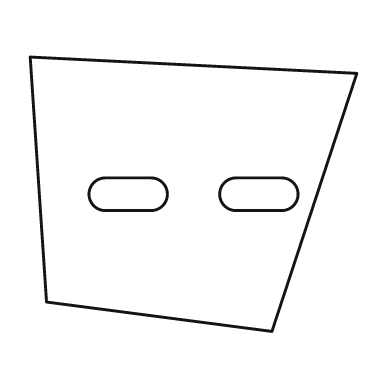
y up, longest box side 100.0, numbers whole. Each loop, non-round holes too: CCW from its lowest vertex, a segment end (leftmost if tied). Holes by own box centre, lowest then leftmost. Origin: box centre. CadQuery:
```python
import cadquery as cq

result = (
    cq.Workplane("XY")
    .moveTo(24.0, -42.0)
    .lineTo(50.0, 37.0)
    .lineTo(-50.0, 42.0)
    .lineTo(-45.0, -33.0)
    .close()
    .moveTo(-27.0, -5.0)
    .lineTo(-13.0, -5.0)
    .threePointArc((-8.0, 0.0), (-13.0, 5.0))
    .lineTo(-27.0, 5.0)
    .threePointArc((-32.0, 0.0), (-27.0, -5.0))
    .close()
    .moveTo(13.0, -5.0)
    .lineTo(27.0, -5.0)
    .threePointArc((32.0, 0.0), (27.0, 5.0))
    .lineTo(13.0, 5.0)
    .threePointArc((8.0, 0.0), (13.0, -5.0))
    .close()
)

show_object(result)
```